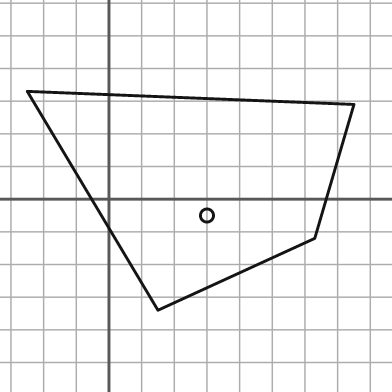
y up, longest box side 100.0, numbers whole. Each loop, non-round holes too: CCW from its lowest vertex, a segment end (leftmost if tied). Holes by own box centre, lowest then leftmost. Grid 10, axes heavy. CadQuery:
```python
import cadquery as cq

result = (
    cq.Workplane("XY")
    .moveTo(15.0, -34.0)
    .lineTo(63.0, -12.0)
    .lineTo(75.0, 29.0)
    .lineTo(-25.0, 33.0)
    .close()
    .moveTo(30.0, -5.0)
    .circle(2.0)
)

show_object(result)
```